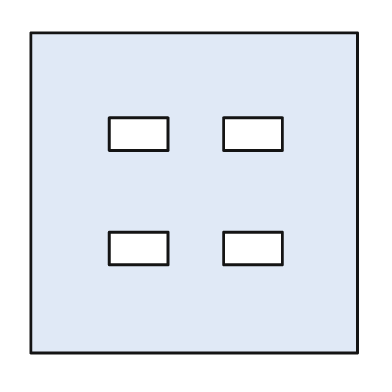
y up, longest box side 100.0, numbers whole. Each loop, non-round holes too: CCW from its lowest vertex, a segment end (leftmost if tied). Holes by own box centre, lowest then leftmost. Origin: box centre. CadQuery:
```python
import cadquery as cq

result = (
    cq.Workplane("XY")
    .moveTo(-50.0, -49.0)
    .lineTo(50.0, -49.0)
    .lineTo(50.0, 49.0)
    .lineTo(-50.0, 49.0)
    .close()
    .moveTo(-26.0, -22.0)
    .lineTo(-8.0, -22.0)
    .lineTo(-8.0, -12.0)
    .lineTo(-26.0, -12.0)
    .close()
    .moveTo(9.0, -22.0)
    .lineTo(27.0, -22.0)
    .lineTo(27.0, -12.0)
    .lineTo(9.0, -12.0)
    .close()
    .moveTo(-26.0, 13.0)
    .lineTo(-8.0, 13.0)
    .lineTo(-8.0, 23.0)
    .lineTo(-26.0, 23.0)
    .close()
    .moveTo(9.0, 13.0)
    .lineTo(27.0, 13.0)
    .lineTo(27.0, 23.0)
    .lineTo(9.0, 23.0)
    .close()
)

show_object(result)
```